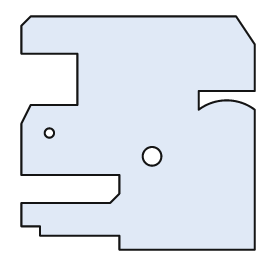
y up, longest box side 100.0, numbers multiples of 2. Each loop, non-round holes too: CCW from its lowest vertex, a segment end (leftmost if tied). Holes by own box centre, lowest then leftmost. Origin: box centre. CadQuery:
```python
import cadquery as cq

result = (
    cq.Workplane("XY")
    .moveTo(-8.0, -50.0)
    .lineTo(50.0, -50.0)
    .lineTo(50.0, 10.0)
    .threePointArc((38.0, 14.0), (26.0, 10.0))
    .lineTo(26.0, 18.0)
    .lineTo(50.0, 18.0)
    .lineTo(50.0, 38.0)
    .lineTo(42.0, 50.0)
    .lineTo(-46.0, 50.0)
    .lineTo(-50.0, 46.0)
    .lineTo(-50.0, 34.0)
    .lineTo(-26.0, 34.0)
    .lineTo(-26.0, 12.0)
    .lineTo(-46.0, 12.0)
    .lineTo(-50.0, 4.0)
    .lineTo(-50.0, -18.0)
    .lineTo(-8.0, -18.0)
    .lineTo(-8.0, -26.0)
    .lineTo(-12.0, -30.0)
    .lineTo(-50.0, -30.0)
    .lineTo(-50.0, -40.0)
    .lineTo(-42.0, -40.0)
    .lineTo(-42.0, -44.0)
    .lineTo(-8.0, -44.0)
    .close()
    .moveTo(6.0, -10.0)
    .circle(4.0)
    .moveTo(-38.0, 0.0)
    .circle(2.0)
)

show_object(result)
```